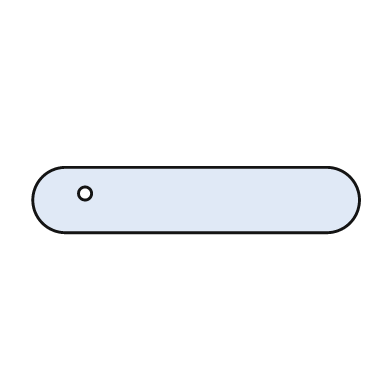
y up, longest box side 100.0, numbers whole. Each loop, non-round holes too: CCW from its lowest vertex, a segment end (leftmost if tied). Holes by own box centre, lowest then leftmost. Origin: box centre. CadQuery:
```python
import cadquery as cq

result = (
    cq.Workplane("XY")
    .moveTo(-40.0, -10.0)
    .lineTo(40.0, -10.0)
    .threePointArc((50.0, 0.0), (40.0, 10.0))
    .lineTo(-40.0, 10.0)
    .threePointArc((-50.0, 0.0), (-40.0, -10.0))
    .close()
    .moveTo(-34.0, 2.0)
    .circle(2.0)
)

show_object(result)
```